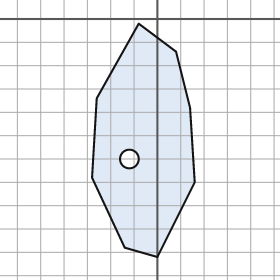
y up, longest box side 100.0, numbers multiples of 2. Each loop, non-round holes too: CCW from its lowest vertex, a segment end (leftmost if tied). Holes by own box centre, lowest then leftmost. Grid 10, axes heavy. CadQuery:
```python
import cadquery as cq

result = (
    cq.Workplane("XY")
    .moveTo(0.0, -102.0)
    .lineTo(16.0, -70.0)
    .lineTo(14.0, -38.0)
    .lineTo(8.0, -14.0)
    .lineTo(-8.0, -2.0)
    .lineTo(-26.0, -34.0)
    .lineTo(-28.0, -68.0)
    .lineTo(-14.0, -98.0)
    .close()
    .moveTo(-12.0, -60.0)
    .circle(4.0)
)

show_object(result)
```